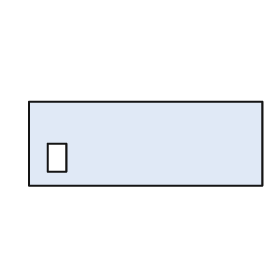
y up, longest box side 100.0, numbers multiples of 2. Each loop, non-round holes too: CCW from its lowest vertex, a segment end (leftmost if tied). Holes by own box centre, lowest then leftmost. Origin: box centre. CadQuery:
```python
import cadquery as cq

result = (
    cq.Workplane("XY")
    .moveTo(-50.0, -18.0)
    .lineTo(50.0, -18.0)
    .lineTo(50.0, 18.0)
    .lineTo(-50.0, 18.0)
    .close()
    .moveTo(-42.0, -12.0)
    .lineTo(-34.0, -12.0)
    .lineTo(-34.0, 0.0)
    .lineTo(-42.0, 0.0)
    .close()
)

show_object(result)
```